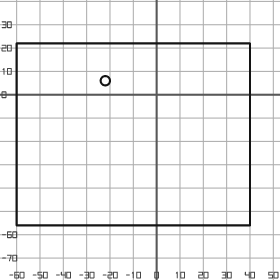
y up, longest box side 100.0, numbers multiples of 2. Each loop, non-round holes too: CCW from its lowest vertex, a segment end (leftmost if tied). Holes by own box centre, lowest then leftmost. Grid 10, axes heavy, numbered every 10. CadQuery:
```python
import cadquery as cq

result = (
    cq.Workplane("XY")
    .moveTo(-60.0, -56.0)
    .lineTo(40.0, -56.0)
    .lineTo(40.0, 22.0)
    .lineTo(-60.0, 22.0)
    .close()
    .moveTo(-22.0, 6.0)
    .circle(2.0)
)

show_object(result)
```